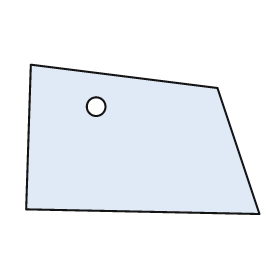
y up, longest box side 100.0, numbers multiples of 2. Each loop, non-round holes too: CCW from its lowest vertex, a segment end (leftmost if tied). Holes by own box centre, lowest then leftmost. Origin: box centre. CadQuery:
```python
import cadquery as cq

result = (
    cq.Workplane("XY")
    .moveTo(50.0, -32.0)
    .lineTo(32.0, 22.0)
    .lineTo(-48.0, 32.0)
    .lineTo(-50.0, -30.0)
    .close()
    .moveTo(-20.0, 14.0)
    .circle(4.0)
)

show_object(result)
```